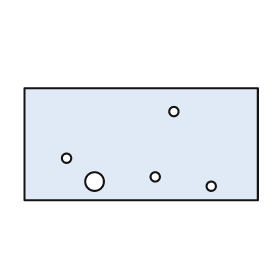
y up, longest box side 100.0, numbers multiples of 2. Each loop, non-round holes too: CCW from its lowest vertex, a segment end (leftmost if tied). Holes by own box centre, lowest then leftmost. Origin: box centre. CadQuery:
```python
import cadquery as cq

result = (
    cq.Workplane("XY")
    .moveTo(-50.0, -24.0)
    .lineTo(50.0, -24.0)
    .lineTo(50.0, 24.0)
    .lineTo(-50.0, 24.0)
    .close()
    .moveTo(30.0, -18.0)
    .circle(2.0)
    .moveTo(-20.0, -16.0)
    .circle(4.0)
    .moveTo(6.0, -14.0)
    .circle(2.0)
    .moveTo(-32.0, -6.0)
    .circle(2.0)
    .moveTo(14.0, 14.0)
    .circle(2.0)
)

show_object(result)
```